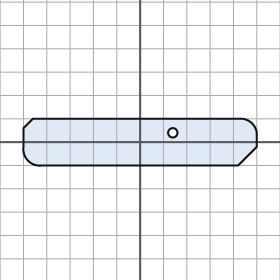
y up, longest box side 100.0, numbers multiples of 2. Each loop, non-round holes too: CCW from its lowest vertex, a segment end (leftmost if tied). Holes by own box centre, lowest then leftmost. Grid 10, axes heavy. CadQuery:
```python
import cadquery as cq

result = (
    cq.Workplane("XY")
    .moveTo(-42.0, -10.0)
    .lineTo(42.0, -10.0)
    .lineTo(50.0, -2.0)
    .lineTo(50.0, 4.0)
    .threePointArc((48.0, 8.0), (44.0, 10.0))
    .lineTo(-46.0, 10.0)
    .lineTo(-50.0, 6.0)
    .lineTo(-50.0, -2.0)
    .threePointArc((-48.0, -8.0), (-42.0, -10.0))
    .close()
    .moveTo(14.0, 4.0)
    .circle(2.0)
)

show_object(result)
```